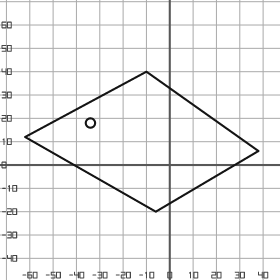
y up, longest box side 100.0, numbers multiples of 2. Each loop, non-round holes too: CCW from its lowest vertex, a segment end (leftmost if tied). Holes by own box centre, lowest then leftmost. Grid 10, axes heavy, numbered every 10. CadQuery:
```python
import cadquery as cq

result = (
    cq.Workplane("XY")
    .moveTo(-6.0, -20.0)
    .lineTo(38.0, 6.0)
    .lineTo(-10.0, 40.0)
    .lineTo(-62.0, 12.0)
    .close()
    .moveTo(-34.0, 18.0)
    .circle(2.0)
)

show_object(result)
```